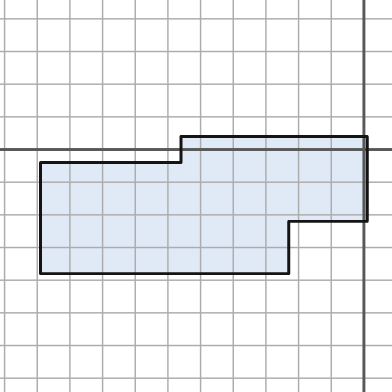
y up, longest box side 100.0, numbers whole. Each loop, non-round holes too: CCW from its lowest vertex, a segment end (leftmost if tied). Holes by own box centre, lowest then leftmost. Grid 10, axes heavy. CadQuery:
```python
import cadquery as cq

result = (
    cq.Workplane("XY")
    .moveTo(-99.0, -38.0)
    .lineTo(-23.0, -38.0)
    .lineTo(-23.0, -22.0)
    .lineTo(1.0, -22.0)
    .lineTo(1.0, 4.0)
    .lineTo(-56.0, 4.0)
    .lineTo(-56.0, -4.0)
    .lineTo(-99.0, -4.0)
    .close()
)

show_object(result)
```